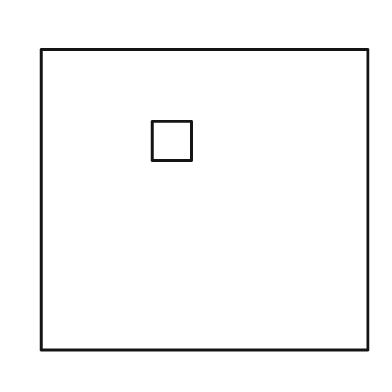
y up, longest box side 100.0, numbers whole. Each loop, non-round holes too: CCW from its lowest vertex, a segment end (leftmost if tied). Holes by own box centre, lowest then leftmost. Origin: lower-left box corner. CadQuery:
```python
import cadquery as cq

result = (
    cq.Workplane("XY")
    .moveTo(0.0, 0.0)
    .lineTo(100.0, 0.0)
    .lineTo(100.0, 92.0)
    .lineTo(0.0, 92.0)
    .close()
    .moveTo(34.0, 58.0)
    .lineTo(46.0, 58.0)
    .lineTo(46.0, 70.0)
    .lineTo(34.0, 70.0)
    .close()
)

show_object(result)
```